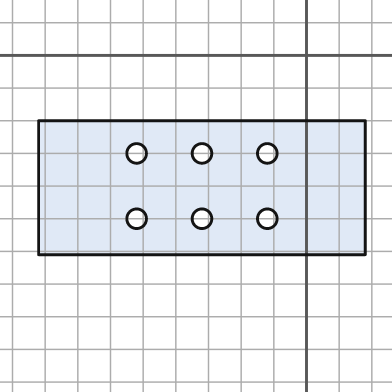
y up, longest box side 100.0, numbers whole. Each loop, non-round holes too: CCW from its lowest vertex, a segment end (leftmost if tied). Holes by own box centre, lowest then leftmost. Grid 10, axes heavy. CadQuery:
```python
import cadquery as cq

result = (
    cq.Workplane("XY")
    .moveTo(-82.0, -61.0)
    .lineTo(18.0, -61.0)
    .lineTo(18.0, -20.0)
    .lineTo(-82.0, -20.0)
    .close()
    .moveTo(-52.0, -50.0)
    .circle(3.0)
    .moveTo(-32.0, -50.0)
    .circle(3.0)
    .moveTo(-12.0, -50.0)
    .circle(3.0)
    .moveTo(-52.0, -30.0)
    .circle(3.0)
    .moveTo(-32.0, -30.0)
    .circle(3.0)
    .moveTo(-12.0, -30.0)
    .circle(3.0)
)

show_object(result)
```